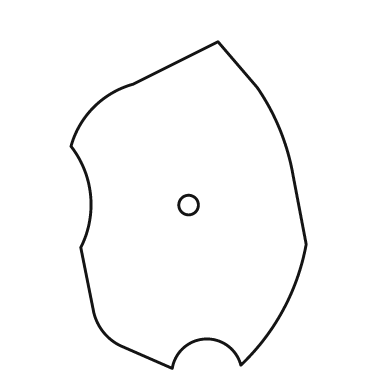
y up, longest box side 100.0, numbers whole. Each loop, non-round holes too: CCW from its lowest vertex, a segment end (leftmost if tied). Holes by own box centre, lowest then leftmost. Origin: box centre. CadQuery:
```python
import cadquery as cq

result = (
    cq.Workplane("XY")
    .moveTo(-5.0, -50.0)
    .threePointArc((5.0, -41.0), (16.0, -49.0))
    .threePointArc((29.0, -32.0), (36.0, -12.0))
    .lineTo(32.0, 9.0)
    .threePointArc((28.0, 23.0), (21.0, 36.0))
    .lineTo(9.0, 50.0)
    .lineTo(-17.0, 37.0)
    .threePointArc((-29.0, 30.0), (-36.0, 18.0))
    .threePointArc((-30.0, 3.0), (-33.0, -13.0))
    .lineTo(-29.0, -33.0)
    .threePointArc((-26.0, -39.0), (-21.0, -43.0))
    .close()
    .moveTo(0.0, 0.0)
    .circle(3.0)
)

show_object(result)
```